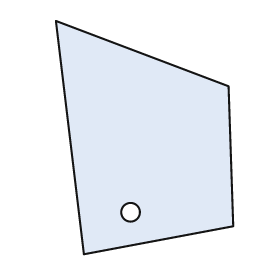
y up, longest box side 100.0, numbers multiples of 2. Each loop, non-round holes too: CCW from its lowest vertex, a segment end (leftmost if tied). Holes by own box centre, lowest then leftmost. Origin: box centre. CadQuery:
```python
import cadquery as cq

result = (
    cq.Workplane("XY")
    .moveTo(-26.0, -50.0)
    .lineTo(38.0, -38.0)
    .lineTo(36.0, 22.0)
    .lineTo(-38.0, 50.0)
    .close()
    .moveTo(-6.0, -32.0)
    .circle(4.0)
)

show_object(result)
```